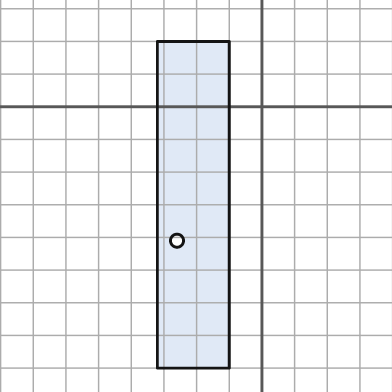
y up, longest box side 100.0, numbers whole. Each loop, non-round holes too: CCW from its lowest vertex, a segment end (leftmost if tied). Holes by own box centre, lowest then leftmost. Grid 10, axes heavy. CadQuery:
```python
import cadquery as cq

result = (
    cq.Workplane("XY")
    .moveTo(-32.0, -80.0)
    .lineTo(-10.0, -80.0)
    .lineTo(-10.0, 20.0)
    .lineTo(-32.0, 20.0)
    .close()
    .moveTo(-26.0, -41.0)
    .circle(2.0)
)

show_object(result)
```